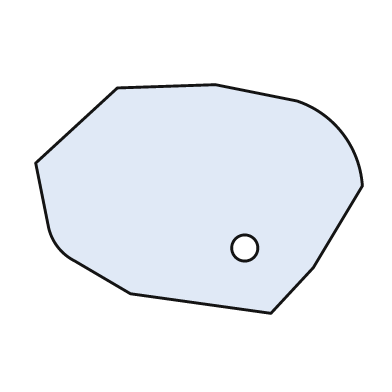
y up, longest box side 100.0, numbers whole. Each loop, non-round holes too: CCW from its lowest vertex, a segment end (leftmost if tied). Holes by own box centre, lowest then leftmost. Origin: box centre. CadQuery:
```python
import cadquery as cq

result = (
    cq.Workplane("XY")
    .moveTo(22.0, -35.0)
    .lineTo(35.0, -21.0)
    .lineTo(50.0, 4.0)
    .threePointArc((44.0, 20.0), (30.0, 30.0))
    .lineTo(5.0, 35.0)
    .lineTo(-25.0, 34.0)
    .lineTo(-50.0, 11.0)
    .lineTo(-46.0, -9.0)
    .threePointArc((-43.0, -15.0), (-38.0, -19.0))
    .lineTo(-21.0, -29.0)
    .close()
    .moveTo(14.0, -15.0)
    .circle(4.0)
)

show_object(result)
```